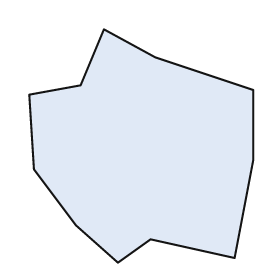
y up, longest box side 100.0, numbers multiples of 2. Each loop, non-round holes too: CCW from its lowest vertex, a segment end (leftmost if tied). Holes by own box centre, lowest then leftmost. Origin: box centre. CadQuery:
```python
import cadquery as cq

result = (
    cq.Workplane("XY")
    .moveTo(-10.0, -50.0)
    .lineTo(4.0, -40.0)
    .lineTo(40.0, -48.0)
    .lineTo(48.0, -6.0)
    .lineTo(48.0, 24.0)
    .lineTo(6.0, 38.0)
    .lineTo(-16.0, 50.0)
    .lineTo(-26.0, 26.0)
    .lineTo(-48.0, 22.0)
    .lineTo(-46.0, -10.0)
    .lineTo(-28.0, -34.0)
    .close()
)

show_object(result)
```